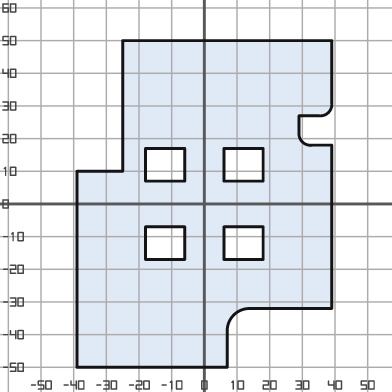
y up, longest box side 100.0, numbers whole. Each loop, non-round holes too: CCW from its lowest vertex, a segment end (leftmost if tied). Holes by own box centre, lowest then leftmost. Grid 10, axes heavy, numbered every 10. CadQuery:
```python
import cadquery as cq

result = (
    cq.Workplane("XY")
    .moveTo(-39.0, -50.0)
    .lineTo(7.0, -50.0)
    .lineTo(7.0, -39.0)
    .threePointArc((9.0, -34.0), (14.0, -32.0))
    .lineTo(39.0, -32.0)
    .lineTo(39.0, 18.0)
    .lineTo(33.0, 18.0)
    .threePointArc((30.0, 19.0), (29.0, 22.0))
    .lineTo(29.0, 27.0)
    .lineTo(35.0, 27.0)
    .threePointArc((38.0, 28.0), (39.0, 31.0))
    .lineTo(39.0, 50.0)
    .lineTo(-25.0, 50.0)
    .lineTo(-25.0, 10.0)
    .lineTo(-39.0, 10.0)
    .close()
    .moveTo(-18.0, -17.0)
    .lineTo(-6.0, -17.0)
    .lineTo(-6.0, -7.0)
    .lineTo(-18.0, -7.0)
    .close()
    .moveTo(6.0, -17.0)
    .lineTo(18.0, -17.0)
    .lineTo(18.0, -7.0)
    .lineTo(6.0, -7.0)
    .close()
    .moveTo(-18.0, 7.0)
    .lineTo(-6.0, 7.0)
    .lineTo(-6.0, 17.0)
    .lineTo(-18.0, 17.0)
    .close()
    .moveTo(6.0, 7.0)
    .lineTo(18.0, 7.0)
    .lineTo(18.0, 17.0)
    .lineTo(6.0, 17.0)
    .close()
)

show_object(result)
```